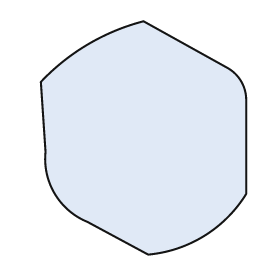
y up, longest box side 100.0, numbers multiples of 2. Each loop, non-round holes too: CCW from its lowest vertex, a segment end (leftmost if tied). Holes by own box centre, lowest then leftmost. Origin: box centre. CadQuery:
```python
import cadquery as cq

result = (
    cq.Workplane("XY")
    .moveTo(2.0, -50.0)
    .threePointArc((26.0, -42.0), (44.0, -24.0))
    .lineTo(44.0, 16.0)
    .threePointArc((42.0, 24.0), (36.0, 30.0))
    .lineTo(0.0, 50.0)
    .threePointArc((-24.0, 40.0), (-44.0, 24.0))
    .lineTo(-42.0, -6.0)
    .threePointArc((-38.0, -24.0), (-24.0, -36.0))
    .close()
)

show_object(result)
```